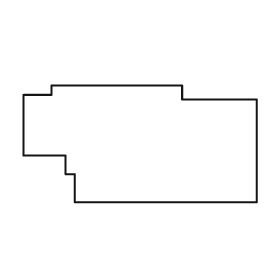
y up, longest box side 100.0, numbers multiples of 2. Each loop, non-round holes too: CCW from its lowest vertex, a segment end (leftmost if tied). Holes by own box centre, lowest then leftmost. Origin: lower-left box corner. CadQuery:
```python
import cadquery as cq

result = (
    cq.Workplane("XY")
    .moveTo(22.0, 0.0)
    .lineTo(100.0, 0.0)
    .lineTo(100.0, 44.0)
    .lineTo(68.0, 44.0)
    .lineTo(68.0, 50.0)
    .lineTo(12.0, 50.0)
    .lineTo(12.0, 46.0)
    .lineTo(0.0, 46.0)
    .lineTo(0.0, 20.0)
    .lineTo(18.0, 20.0)
    .lineTo(18.0, 12.0)
    .lineTo(22.0, 12.0)
    .close()
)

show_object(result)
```